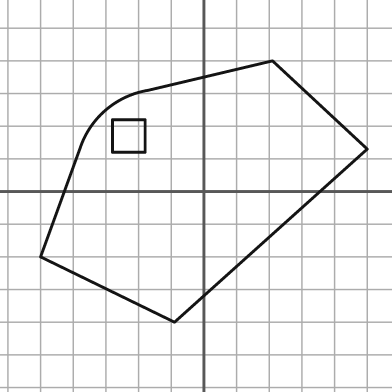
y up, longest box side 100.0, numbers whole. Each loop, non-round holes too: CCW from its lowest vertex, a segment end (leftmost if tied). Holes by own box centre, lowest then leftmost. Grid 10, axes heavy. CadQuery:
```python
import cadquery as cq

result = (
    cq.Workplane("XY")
    .moveTo(-9.0, -40.0)
    .lineTo(50.0, 13.0)
    .lineTo(21.0, 40.0)
    .lineTo(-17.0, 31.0)
    .threePointArc((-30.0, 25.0), (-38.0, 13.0))
    .lineTo(-50.0, -20.0)
    .close()
    .moveTo(-28.0, 12.0)
    .lineTo(-18.0, 12.0)
    .lineTo(-18.0, 22.0)
    .lineTo(-28.0, 22.0)
    .close()
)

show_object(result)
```